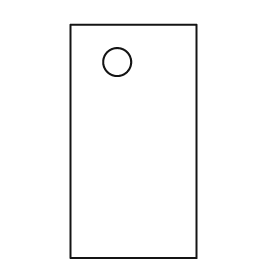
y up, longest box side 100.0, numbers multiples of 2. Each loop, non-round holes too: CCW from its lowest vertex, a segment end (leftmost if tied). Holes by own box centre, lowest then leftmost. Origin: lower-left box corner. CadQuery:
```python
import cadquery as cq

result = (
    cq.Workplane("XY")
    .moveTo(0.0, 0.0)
    .lineTo(54.0, 0.0)
    .lineTo(54.0, 100.0)
    .lineTo(0.0, 100.0)
    .close()
    .moveTo(20.0, 84.0)
    .circle(6.0)
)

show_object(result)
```